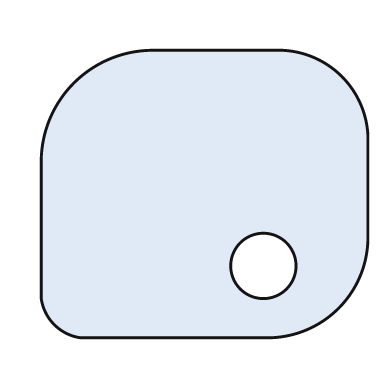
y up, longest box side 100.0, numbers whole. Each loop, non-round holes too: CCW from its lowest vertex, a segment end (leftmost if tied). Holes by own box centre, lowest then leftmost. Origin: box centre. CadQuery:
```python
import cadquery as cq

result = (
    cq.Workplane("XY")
    .moveTo(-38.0, -44.0)
    .lineTo(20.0, -44.0)
    .threePointArc((41.0, -35.0), (50.0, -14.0))
    .lineTo(50.0, 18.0)
    .threePointArc((42.0, 36.0), (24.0, 44.0))
    .lineTo(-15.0, 44.0)
    .threePointArc((-40.0, 34.0), (-50.0, 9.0))
    .lineTo(-50.0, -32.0)
    .threePointArc((-46.0, -40.0), (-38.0, -44.0))
    .close()
    .moveTo(18.0, -22.0)
    .circle(10.0)
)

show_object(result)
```